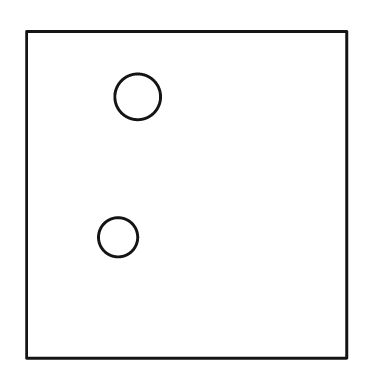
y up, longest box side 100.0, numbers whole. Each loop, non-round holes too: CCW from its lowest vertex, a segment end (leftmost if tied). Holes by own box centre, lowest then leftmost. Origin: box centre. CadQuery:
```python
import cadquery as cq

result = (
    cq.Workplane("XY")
    .moveTo(-49.0, -50.0)
    .lineTo(49.0, -50.0)
    .lineTo(49.0, 50.0)
    .lineTo(-49.0, 50.0)
    .close()
    .moveTo(-21.0, -13.0)
    .circle(6.0)
    .moveTo(-15.0, 30.0)
    .circle(7.0)
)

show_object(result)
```